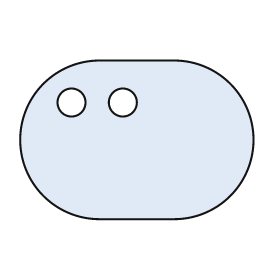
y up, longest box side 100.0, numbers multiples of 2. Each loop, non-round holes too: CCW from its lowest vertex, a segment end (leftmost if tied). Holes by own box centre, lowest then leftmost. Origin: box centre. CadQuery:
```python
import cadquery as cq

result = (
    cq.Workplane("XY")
    .moveTo(-16.0, -34.0)
    .lineTo(16.0, -34.0)
    .threePointArc((50.0, 0.0), (16.0, 34.0))
    .lineTo(-16.0, 34.0)
    .threePointArc((-50.0, 0.0), (-16.0, -34.0))
    .close()
    .moveTo(-28.0, 16.0)
    .circle(6.0)
    .moveTo(-6.0, 16.0)
    .circle(6.0)
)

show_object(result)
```